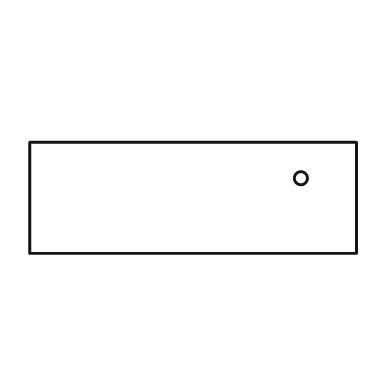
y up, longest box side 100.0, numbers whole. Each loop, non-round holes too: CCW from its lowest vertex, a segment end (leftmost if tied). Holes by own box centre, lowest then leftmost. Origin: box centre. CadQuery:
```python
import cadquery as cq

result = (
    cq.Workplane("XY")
    .moveTo(-50.0, -17.0)
    .lineTo(50.0, -17.0)
    .lineTo(50.0, 17.0)
    .lineTo(-50.0, 17.0)
    .close()
    .moveTo(33.0, 6.0)
    .circle(2.0)
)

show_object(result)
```